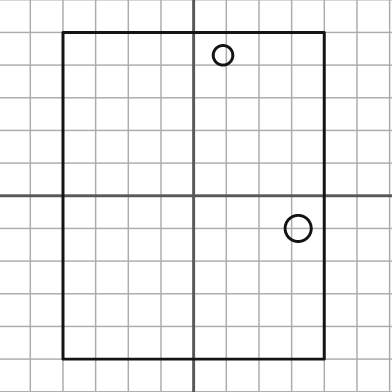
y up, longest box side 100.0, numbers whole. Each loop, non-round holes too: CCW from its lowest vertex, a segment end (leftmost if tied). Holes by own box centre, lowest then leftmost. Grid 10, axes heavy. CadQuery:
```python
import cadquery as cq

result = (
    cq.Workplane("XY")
    .moveTo(-40.0, -50.0)
    .lineTo(40.0, -50.0)
    .lineTo(40.0, 50.0)
    .lineTo(-40.0, 50.0)
    .close()
    .moveTo(32.0, -10.0)
    .circle(4.0)
    .moveTo(9.0, 43.0)
    .circle(3.0)
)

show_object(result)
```